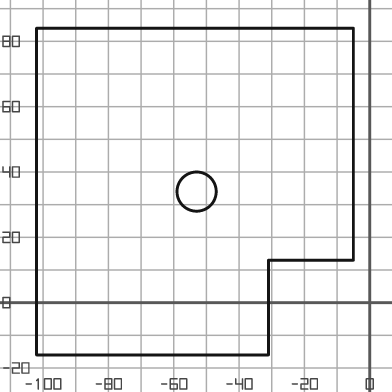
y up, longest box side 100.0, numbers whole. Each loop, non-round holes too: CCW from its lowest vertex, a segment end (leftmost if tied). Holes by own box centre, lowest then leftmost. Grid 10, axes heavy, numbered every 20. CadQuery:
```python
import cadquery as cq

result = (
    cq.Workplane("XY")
    .moveTo(-102.0, -16.0)
    .lineTo(-31.0, -16.0)
    .lineTo(-31.0, 13.0)
    .lineTo(-5.0, 13.0)
    .lineTo(-5.0, 84.0)
    .lineTo(-102.0, 84.0)
    .close()
    .moveTo(-53.0, 34.0)
    .circle(6.0)
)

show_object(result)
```